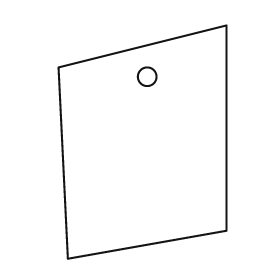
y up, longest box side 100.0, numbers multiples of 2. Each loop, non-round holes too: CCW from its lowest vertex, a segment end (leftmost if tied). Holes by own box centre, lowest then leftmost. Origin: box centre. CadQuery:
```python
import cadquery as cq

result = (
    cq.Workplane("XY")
    .moveTo(-32.0, -50.0)
    .lineTo(36.0, -38.0)
    .lineTo(36.0, 50.0)
    .lineTo(-36.0, 32.0)
    .close()
    .moveTo(2.0, 28.0)
    .circle(4.0)
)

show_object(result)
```